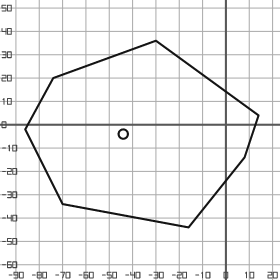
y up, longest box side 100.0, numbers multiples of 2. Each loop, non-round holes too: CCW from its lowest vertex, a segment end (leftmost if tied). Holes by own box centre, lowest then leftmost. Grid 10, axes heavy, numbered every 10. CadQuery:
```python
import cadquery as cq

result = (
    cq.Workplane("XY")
    .moveTo(-16.0, -44.0)
    .lineTo(8.0, -14.0)
    .lineTo(14.0, 4.0)
    .lineTo(-30.0, 36.0)
    .lineTo(-74.0, 20.0)
    .lineTo(-86.0, -2.0)
    .lineTo(-70.0, -34.0)
    .close()
    .moveTo(-44.0, -4.0)
    .circle(2.0)
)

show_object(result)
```